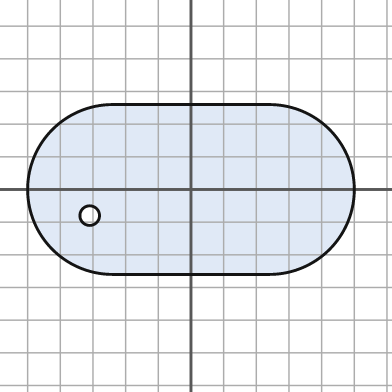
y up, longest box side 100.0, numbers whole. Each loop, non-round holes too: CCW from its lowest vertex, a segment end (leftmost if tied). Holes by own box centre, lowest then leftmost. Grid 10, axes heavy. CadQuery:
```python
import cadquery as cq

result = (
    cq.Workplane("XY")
    .moveTo(-24.0, -26.0)
    .lineTo(24.0, -26.0)
    .threePointArc((50.0, 0.0), (24.0, 26.0))
    .lineTo(-24.0, 26.0)
    .threePointArc((-50.0, 0.0), (-24.0, -26.0))
    .close()
    .moveTo(-31.0, -8.0)
    .circle(3.0)
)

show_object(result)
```